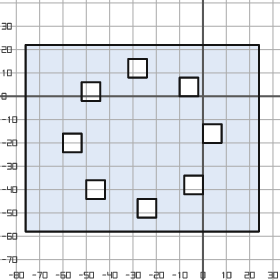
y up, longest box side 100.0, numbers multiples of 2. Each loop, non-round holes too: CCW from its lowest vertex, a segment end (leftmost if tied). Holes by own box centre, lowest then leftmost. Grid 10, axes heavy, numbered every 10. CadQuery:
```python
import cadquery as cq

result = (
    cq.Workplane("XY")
    .moveTo(-76.0, -58.0)
    .lineTo(24.0, -58.0)
    .lineTo(24.0, 22.0)
    .lineTo(-76.0, 22.0)
    .close()
    .moveTo(-28.0, -52.0)
    .lineTo(-20.0, -52.0)
    .lineTo(-20.0, -44.0)
    .lineTo(-28.0, -44.0)
    .close()
    .moveTo(-50.0, -44.0)
    .lineTo(-42.0, -44.0)
    .lineTo(-42.0, -36.0)
    .lineTo(-50.0, -36.0)
    .close()
    .moveTo(-8.0, -42.0)
    .lineTo(0.0, -42.0)
    .lineTo(0.0, -34.0)
    .lineTo(-8.0, -34.0)
    .close()
    .moveTo(-60.0, -24.0)
    .lineTo(-52.0, -24.0)
    .lineTo(-52.0, -16.0)
    .lineTo(-60.0, -16.0)
    .close()
    .moveTo(0.0, -20.0)
    .lineTo(8.0, -20.0)
    .lineTo(8.0, -12.0)
    .lineTo(0.0, -12.0)
    .close()
    .moveTo(-52.0, -2.0)
    .lineTo(-44.0, -2.0)
    .lineTo(-44.0, 6.0)
    .lineTo(-52.0, 6.0)
    .close()
    .moveTo(-10.0, 0.0)
    .lineTo(-2.0, 0.0)
    .lineTo(-2.0, 8.0)
    .lineTo(-10.0, 8.0)
    .close()
    .moveTo(-32.0, 8.0)
    .lineTo(-24.0, 8.0)
    .lineTo(-24.0, 16.0)
    .lineTo(-32.0, 16.0)
    .close()
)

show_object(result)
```